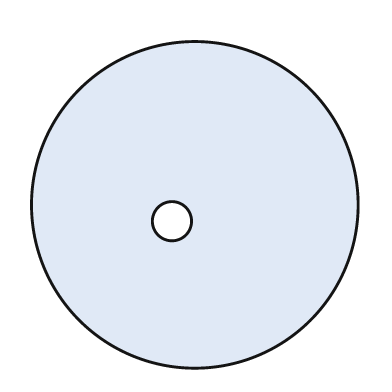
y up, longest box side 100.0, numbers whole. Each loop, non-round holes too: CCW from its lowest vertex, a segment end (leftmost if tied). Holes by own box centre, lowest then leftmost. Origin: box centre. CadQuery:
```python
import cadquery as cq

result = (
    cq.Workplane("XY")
    .moveTo(0.0, 0.0)
    .circle(50.0)
    .moveTo(-7.0, -5.0)
    .circle(6.0)
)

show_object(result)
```